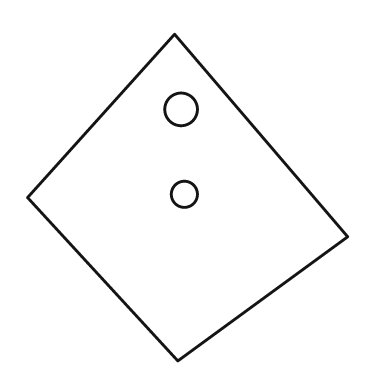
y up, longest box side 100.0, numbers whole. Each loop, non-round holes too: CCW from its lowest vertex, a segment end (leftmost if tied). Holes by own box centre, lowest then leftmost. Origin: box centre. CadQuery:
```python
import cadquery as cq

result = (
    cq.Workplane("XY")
    .moveTo(-3.0, -50.0)
    .lineTo(49.0, -12.0)
    .lineTo(-4.0, 50.0)
    .lineTo(-49.0, 0.0)
    .close()
    .moveTo(-1.0, 1.0)
    .circle(4.0)
    .moveTo(-2.0, 27.0)
    .circle(5.0)
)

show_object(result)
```